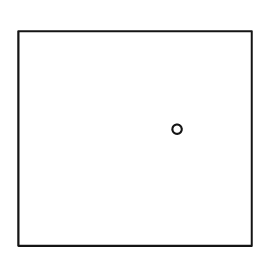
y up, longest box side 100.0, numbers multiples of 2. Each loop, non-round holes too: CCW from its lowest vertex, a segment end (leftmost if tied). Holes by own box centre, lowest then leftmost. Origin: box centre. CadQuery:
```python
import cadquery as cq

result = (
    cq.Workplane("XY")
    .moveTo(-50.0, -46.0)
    .lineTo(50.0, -46.0)
    .lineTo(50.0, 46.0)
    .lineTo(-50.0, 46.0)
    .close()
    .moveTo(18.0, 4.0)
    .circle(2.0)
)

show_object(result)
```